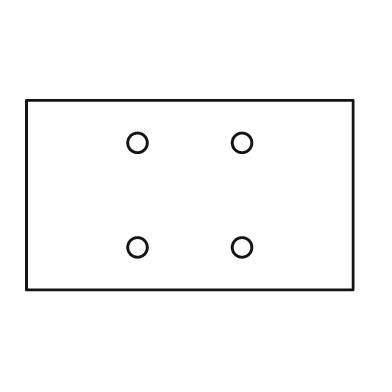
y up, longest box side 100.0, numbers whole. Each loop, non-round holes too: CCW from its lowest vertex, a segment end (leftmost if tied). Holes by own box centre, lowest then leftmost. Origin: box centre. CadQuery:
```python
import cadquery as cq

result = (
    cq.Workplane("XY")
    .moveTo(-50.0, -29.0)
    .lineTo(50.0, -29.0)
    .lineTo(50.0, 29.0)
    .lineTo(-50.0, 29.0)
    .close()
    .moveTo(-16.0, -16.0)
    .circle(3.0)
    .moveTo(16.0, -16.0)
    .circle(3.0)
    .moveTo(-16.0, 16.0)
    .circle(3.0)
    .moveTo(16.0, 16.0)
    .circle(3.0)
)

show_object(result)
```